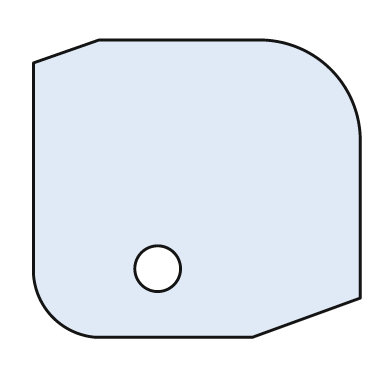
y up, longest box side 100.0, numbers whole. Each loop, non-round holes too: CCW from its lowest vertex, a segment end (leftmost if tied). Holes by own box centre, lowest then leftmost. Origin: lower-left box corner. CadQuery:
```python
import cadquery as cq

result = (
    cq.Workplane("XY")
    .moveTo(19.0, 0.0)
    .lineTo(67.0, 0.0)
    .lineTo(100.0, 12.0)
    .lineTo(100.0, 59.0)
    .threePointArc((91.0, 82.0), (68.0, 91.0))
    .lineTo(20.0, 91.0)
    .lineTo(0.0, 84.0)
    .lineTo(0.0, 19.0)
    .threePointArc((6.0, 6.0), (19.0, 0.0))
    .close()
    .moveTo(38.0, 21.0)
    .circle(7.0)
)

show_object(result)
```